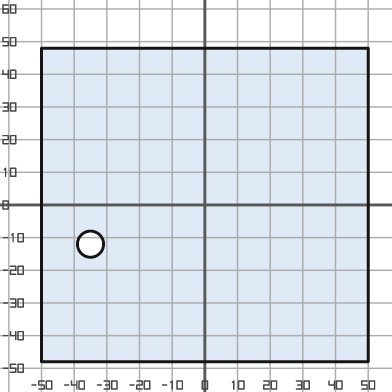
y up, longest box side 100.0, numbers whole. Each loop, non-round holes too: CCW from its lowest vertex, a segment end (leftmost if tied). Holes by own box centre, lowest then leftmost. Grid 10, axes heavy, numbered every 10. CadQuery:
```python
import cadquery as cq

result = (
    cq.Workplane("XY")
    .moveTo(-50.0, -48.0)
    .lineTo(50.0, -48.0)
    .lineTo(50.0, 48.0)
    .lineTo(-50.0, 48.0)
    .close()
    .moveTo(-35.0, -12.0)
    .circle(4.0)
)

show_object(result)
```